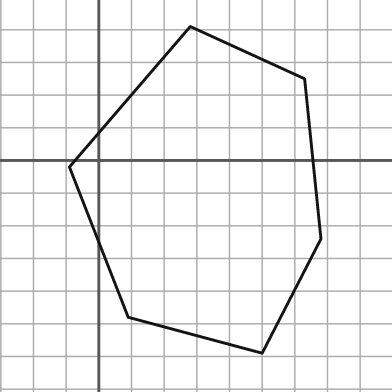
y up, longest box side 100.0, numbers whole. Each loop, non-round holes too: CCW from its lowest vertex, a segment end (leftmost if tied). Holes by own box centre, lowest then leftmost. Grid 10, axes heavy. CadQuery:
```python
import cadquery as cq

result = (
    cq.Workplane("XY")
    .moveTo(50.0, -59.0)
    .lineTo(68.0, -24.0)
    .lineTo(63.0, 25.0)
    .lineTo(28.0, 41.0)
    .lineTo(-9.0, -2.0)
    .lineTo(9.0, -48.0)
    .close()
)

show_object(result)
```